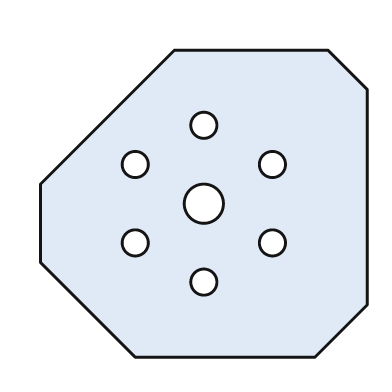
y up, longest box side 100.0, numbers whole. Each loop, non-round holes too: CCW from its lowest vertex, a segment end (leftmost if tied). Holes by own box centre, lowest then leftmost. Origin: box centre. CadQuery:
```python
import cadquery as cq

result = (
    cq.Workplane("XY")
    .moveTo(-21.0, -47.0)
    .lineTo(34.0, -47.0)
    .lineTo(50.0, -31.0)
    .lineTo(50.0, 35.0)
    .lineTo(38.0, 47.0)
    .lineTo(-9.0, 47.0)
    .lineTo(-50.0, 6.0)
    .lineTo(-50.0, -18.0)
    .close()
    .moveTo(0.0, -24.0)
    .circle(4.0)
    .moveTo(-21.0, -12.0)
    .circle(4.0)
    .moveTo(21.0, -12.0)
    .circle(4.0)
    .moveTo(0.0, 0.0)
    .circle(6.0)
    .moveTo(-21.0, 12.0)
    .circle(4.0)
    .moveTo(21.0, 12.0)
    .circle(4.0)
    .moveTo(0.0, 24.0)
    .circle(4.0)
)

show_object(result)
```